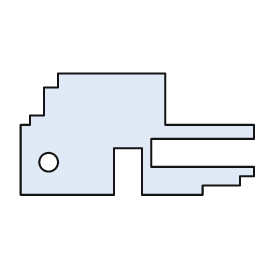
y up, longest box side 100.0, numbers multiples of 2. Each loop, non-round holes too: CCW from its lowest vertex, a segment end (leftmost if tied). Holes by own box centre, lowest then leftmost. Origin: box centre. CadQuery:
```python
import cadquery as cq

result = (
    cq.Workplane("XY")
    .moveTo(-50.0, -26.0)
    .lineTo(-10.0, -26.0)
    .lineTo(-10.0, -6.0)
    .lineTo(2.0, -6.0)
    .lineTo(2.0, -26.0)
    .lineTo(28.0, -26.0)
    .lineTo(28.0, -22.0)
    .lineTo(44.0, -22.0)
    .lineTo(44.0, -18.0)
    .lineTo(50.0, -18.0)
    .lineTo(50.0, -14.0)
    .lineTo(6.0, -14.0)
    .lineTo(6.0, -2.0)
    .lineTo(50.0, -2.0)
    .lineTo(50.0, 4.0)
    .lineTo(12.0, 4.0)
    .lineTo(12.0, 26.0)
    .lineTo(-34.0, 26.0)
    .lineTo(-34.0, 20.0)
    .lineTo(-40.0, 20.0)
    .lineTo(-40.0, 8.0)
    .lineTo(-46.0, 8.0)
    .lineTo(-46.0, 4.0)
    .lineTo(-50.0, 4.0)
    .close()
    .moveTo(-38.0, -12.0)
    .circle(4.0)
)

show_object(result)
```